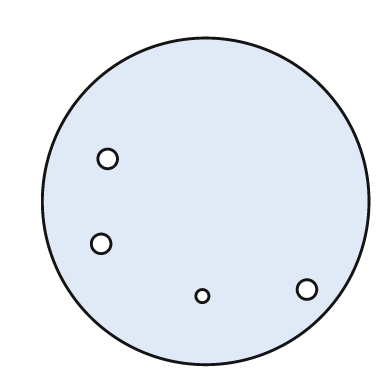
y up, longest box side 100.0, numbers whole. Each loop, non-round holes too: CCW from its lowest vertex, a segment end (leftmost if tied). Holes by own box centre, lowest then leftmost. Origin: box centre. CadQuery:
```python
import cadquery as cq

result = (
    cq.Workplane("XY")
    .moveTo(0.0, 0.0)
    .circle(50.0)
    .moveTo(-1.0, -29.0)
    .circle(2.0)
    .moveTo(31.0, -27.0)
    .circle(3.0)
    .moveTo(-32.0, -13.0)
    .circle(3.0)
    .moveTo(-30.0, 13.0)
    .circle(3.0)
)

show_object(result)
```